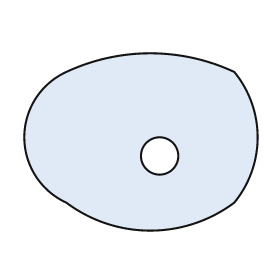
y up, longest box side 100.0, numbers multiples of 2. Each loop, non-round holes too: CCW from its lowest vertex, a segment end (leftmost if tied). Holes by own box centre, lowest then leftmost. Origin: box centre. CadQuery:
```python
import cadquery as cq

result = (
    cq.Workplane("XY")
    .moveTo(-32.0, -26.0)
    .threePointArc((4.0, -38.0), (40.0, -26.0))
    .threePointArc((50.0, 2.0), (40.0, 30.0))
    .threePointArc((4.0, 38.0), (-32.0, 30.0))
    .threePointArc((-50.0, 2.0), (-32.0, -26.0))
    .close()
    .moveTo(8.0, -6.0)
    .circle(8.0)
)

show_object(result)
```